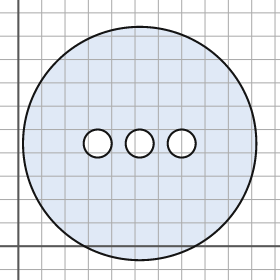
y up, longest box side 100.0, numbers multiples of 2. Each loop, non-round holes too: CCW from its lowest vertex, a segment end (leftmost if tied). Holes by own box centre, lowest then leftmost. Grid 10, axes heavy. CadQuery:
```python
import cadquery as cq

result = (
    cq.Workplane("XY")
    .moveTo(52.0, 44.0)
    .circle(50.0)
    .moveTo(34.0, 44.0)
    .circle(6.0)
    .moveTo(52.0, 44.0)
    .circle(6.0)
    .moveTo(70.0, 44.0)
    .circle(6.0)
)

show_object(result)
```